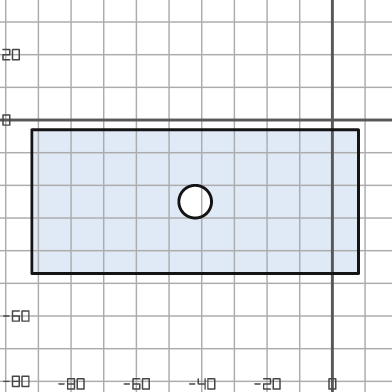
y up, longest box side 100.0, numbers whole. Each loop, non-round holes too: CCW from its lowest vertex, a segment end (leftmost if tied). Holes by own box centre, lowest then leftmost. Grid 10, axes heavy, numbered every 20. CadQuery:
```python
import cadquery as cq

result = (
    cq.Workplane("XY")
    .moveTo(-92.0, -47.0)
    .lineTo(8.0, -47.0)
    .lineTo(8.0, -3.0)
    .lineTo(-92.0, -3.0)
    .close()
    .moveTo(-42.0, -25.0)
    .circle(5.0)
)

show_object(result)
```